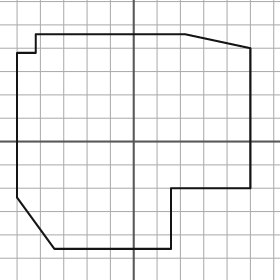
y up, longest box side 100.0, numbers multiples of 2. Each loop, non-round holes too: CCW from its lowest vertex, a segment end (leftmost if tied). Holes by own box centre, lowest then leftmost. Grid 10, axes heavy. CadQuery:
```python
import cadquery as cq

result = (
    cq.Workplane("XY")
    .moveTo(-34.0, -46.0)
    .lineTo(16.0, -46.0)
    .lineTo(16.0, -20.0)
    .lineTo(50.0, -20.0)
    .lineTo(50.0, 40.0)
    .lineTo(22.0, 46.0)
    .lineTo(-42.0, 46.0)
    .lineTo(-42.0, 38.0)
    .lineTo(-50.0, 38.0)
    .lineTo(-50.0, -24.0)
    .close()
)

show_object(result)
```